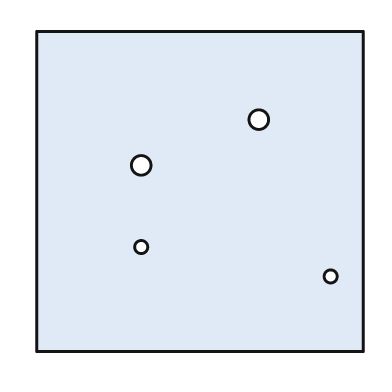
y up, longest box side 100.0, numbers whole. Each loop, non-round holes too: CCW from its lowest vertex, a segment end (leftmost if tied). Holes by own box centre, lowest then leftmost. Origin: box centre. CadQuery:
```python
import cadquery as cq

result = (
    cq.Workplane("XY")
    .moveTo(-50.0, -49.0)
    .lineTo(50.0, -49.0)
    .lineTo(50.0, 49.0)
    .lineTo(-50.0, 49.0)
    .close()
    .moveTo(40.0, -26.0)
    .circle(2.0)
    .moveTo(-18.0, -17.0)
    .circle(2.0)
    .moveTo(-18.0, 8.0)
    .circle(3.0)
    .moveTo(18.0, 22.0)
    .circle(3.0)
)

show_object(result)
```